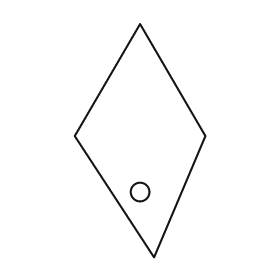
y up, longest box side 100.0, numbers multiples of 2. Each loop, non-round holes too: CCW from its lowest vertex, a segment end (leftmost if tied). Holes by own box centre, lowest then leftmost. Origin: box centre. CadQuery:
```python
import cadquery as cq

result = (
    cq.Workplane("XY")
    .moveTo(6.0, -50.0)
    .lineTo(28.0, 2.0)
    .lineTo(0.0, 50.0)
    .lineTo(-28.0, 2.0)
    .close()
    .moveTo(0.0, -22.0)
    .circle(4.0)
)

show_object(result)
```